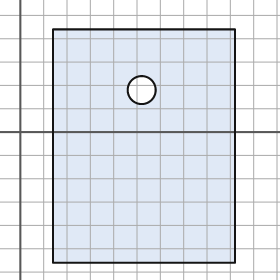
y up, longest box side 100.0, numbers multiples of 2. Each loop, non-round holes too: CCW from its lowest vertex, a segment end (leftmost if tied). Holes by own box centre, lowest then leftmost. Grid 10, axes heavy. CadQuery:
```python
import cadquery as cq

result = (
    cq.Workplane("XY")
    .moveTo(14.0, -56.0)
    .lineTo(92.0, -56.0)
    .lineTo(92.0, 44.0)
    .lineTo(14.0, 44.0)
    .close()
    .moveTo(52.0, 18.0)
    .circle(6.0)
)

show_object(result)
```